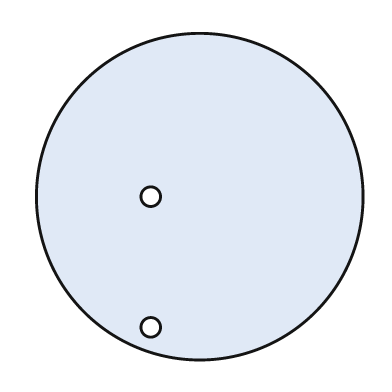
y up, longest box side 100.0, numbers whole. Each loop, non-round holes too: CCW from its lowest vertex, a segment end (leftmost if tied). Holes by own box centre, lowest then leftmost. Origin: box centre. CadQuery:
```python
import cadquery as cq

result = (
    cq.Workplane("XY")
    .moveTo(0.0, 0.0)
    .circle(50.0)
    .moveTo(-15.0, -40.0)
    .circle(3.0)
    .moveTo(-15.0, 0.0)
    .circle(3.0)
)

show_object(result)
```